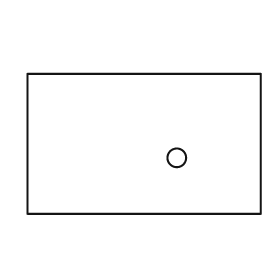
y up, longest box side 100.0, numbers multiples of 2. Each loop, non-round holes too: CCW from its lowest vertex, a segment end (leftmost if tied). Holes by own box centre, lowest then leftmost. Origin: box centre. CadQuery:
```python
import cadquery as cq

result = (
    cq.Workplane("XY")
    .moveTo(-50.0, -30.0)
    .lineTo(50.0, -30.0)
    .lineTo(50.0, 30.0)
    .lineTo(-50.0, 30.0)
    .close()
    .moveTo(14.0, -6.0)
    .circle(4.0)
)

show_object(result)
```